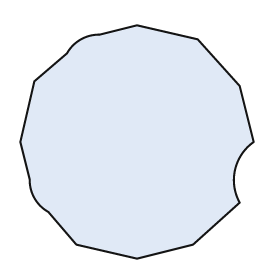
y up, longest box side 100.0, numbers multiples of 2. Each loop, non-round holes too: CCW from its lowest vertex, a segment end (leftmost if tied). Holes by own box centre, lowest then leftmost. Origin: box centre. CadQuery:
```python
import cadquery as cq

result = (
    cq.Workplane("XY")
    .moveTo(0.0, -50.0)
    .lineTo(24.0, -44.0)
    .lineTo(44.0, -26.0)
    .threePointArc((42.0, -12.0), (50.0, 0.0))
    .lineTo(44.0, 24.0)
    .lineTo(26.0, 44.0)
    .lineTo(0.0, 50.0)
    .lineTo(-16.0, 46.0)
    .threePointArc((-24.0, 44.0), (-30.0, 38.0))
    .lineTo(-44.0, 26.0)
    .lineTo(-50.0, 0.0)
    .lineTo(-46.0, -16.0)
    .threePointArc((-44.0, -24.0), (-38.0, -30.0))
    .lineTo(-26.0, -44.0)
    .close()
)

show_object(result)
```